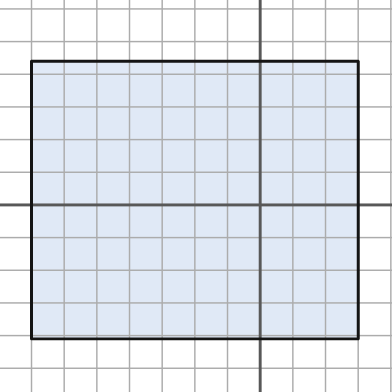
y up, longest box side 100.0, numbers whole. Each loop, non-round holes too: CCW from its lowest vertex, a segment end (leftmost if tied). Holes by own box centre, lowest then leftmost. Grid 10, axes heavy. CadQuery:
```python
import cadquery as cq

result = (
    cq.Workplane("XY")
    .moveTo(-70.0, -41.0)
    .lineTo(30.0, -41.0)
    .lineTo(30.0, 44.0)
    .lineTo(-70.0, 44.0)
    .close()
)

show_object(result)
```